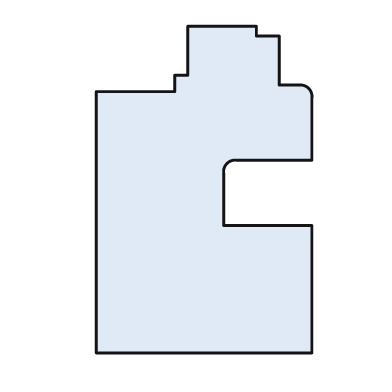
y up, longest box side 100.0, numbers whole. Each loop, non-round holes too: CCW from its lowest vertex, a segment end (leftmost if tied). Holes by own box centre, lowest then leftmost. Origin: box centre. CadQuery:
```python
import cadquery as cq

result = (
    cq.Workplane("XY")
    .moveTo(-33.0, -50.0)
    .lineTo(33.0, -50.0)
    .lineTo(33.0, -11.0)
    .lineTo(6.0, -11.0)
    .lineTo(6.0, 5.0)
    .threePointArc((7.0, 8.0), (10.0, 9.0))
    .lineTo(33.0, 9.0)
    .lineTo(33.0, 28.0)
    .threePointArc((32.0, 31.0), (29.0, 32.0))
    .lineTo(23.0, 32.0)
    .lineTo(23.0, 47.0)
    .lineTo(16.0, 47.0)
    .lineTo(16.0, 50.0)
    .lineTo(-5.0, 50.0)
    .lineTo(-5.0, 35.0)
    .lineTo(-9.0, 35.0)
    .lineTo(-9.0, 30.0)
    .lineTo(-33.0, 30.0)
    .close()
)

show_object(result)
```